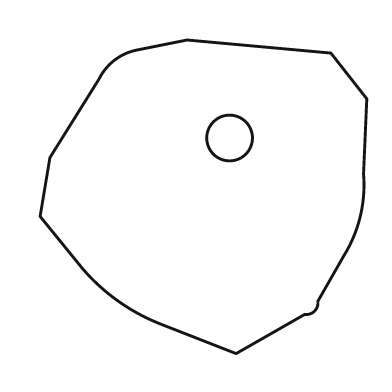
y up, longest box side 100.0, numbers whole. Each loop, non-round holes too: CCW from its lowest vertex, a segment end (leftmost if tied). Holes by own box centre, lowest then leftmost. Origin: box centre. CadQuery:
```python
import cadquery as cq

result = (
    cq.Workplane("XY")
    .moveTo(10.0, -48.0)
    .lineTo(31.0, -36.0)
    .threePointArc((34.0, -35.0), (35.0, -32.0))
    .lineTo(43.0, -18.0)
    .threePointArc((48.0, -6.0), (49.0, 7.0))
    .lineTo(50.0, 30.0)
    .lineTo(39.0, 44.0)
    .lineTo(-5.0, 48.0)
    .lineTo(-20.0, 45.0)
    .threePointArc((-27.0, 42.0), (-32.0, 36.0))
    .lineTo(-47.0, 12.0)
    .lineTo(-50.0, -6.0)
    .lineTo(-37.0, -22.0)
    .threePointArc((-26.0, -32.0), (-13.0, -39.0))
    .close()
    .moveTo(8.0, 18.0)
    .circle(7.0)
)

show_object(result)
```